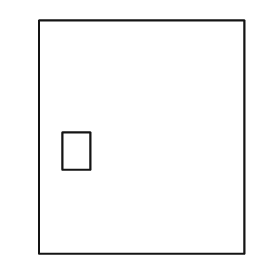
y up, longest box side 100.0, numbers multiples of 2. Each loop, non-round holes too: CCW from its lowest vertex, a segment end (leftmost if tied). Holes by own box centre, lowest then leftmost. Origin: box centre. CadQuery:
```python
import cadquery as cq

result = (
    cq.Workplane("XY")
    .moveTo(-44.0, -50.0)
    .lineTo(44.0, -50.0)
    .lineTo(44.0, 50.0)
    .lineTo(-44.0, 50.0)
    .close()
    .moveTo(-34.0, -14.0)
    .lineTo(-22.0, -14.0)
    .lineTo(-22.0, 2.0)
    .lineTo(-34.0, 2.0)
    .close()
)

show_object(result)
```